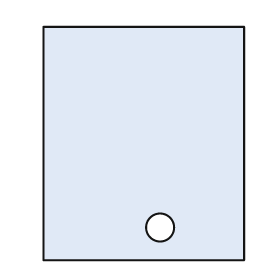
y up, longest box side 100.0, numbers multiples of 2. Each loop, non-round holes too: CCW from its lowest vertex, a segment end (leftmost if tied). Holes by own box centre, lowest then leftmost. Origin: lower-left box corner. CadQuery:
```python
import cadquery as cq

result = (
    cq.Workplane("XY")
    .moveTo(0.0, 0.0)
    .lineTo(86.0, 0.0)
    .lineTo(86.0, 100.0)
    .lineTo(0.0, 100.0)
    .close()
    .moveTo(50.0, 14.0)
    .circle(6.0)
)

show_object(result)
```